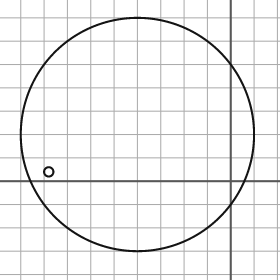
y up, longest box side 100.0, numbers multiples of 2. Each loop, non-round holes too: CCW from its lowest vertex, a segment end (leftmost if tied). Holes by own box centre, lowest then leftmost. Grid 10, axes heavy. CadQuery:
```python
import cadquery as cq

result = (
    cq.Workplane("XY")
    .moveTo(-40.0, 20.0)
    .circle(50.0)
    .moveTo(-78.0, 4.0)
    .circle(2.0)
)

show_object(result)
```